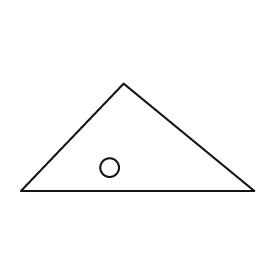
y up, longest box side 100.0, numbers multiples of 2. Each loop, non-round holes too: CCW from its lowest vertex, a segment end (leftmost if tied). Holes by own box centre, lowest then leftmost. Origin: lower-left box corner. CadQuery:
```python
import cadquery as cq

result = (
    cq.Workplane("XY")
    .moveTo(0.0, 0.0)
    .lineTo(100.0, 0.0)
    .lineTo(44.0, 46.0)
    .close()
    .moveTo(38.0, 10.0)
    .circle(4.0)
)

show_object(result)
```